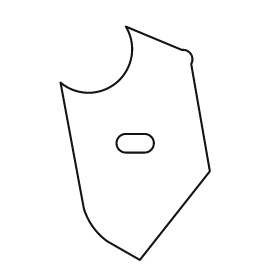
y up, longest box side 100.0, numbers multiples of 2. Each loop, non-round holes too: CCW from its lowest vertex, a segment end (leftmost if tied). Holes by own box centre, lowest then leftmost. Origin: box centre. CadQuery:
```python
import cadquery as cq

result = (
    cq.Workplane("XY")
    .moveTo(2.0, -50.0)
    .lineTo(32.0, -12.0)
    .lineTo(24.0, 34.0)
    .threePointArc((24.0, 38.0), (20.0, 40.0))
    .lineTo(-4.0, 50.0)
    .threePointArc((-8.0, 26.0), (-32.0, 26.0))
    .lineTo(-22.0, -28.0)
    .threePointArc((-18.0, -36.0), (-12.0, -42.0))
    .close()
    .moveTo(-4.0, -4.0)
    .lineTo(4.0, -4.0)
    .threePointArc((8.0, 0.0), (4.0, 4.0))
    .lineTo(-4.0, 4.0)
    .threePointArc((-8.0, 0.0), (-4.0, -4.0))
    .close()
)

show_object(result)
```